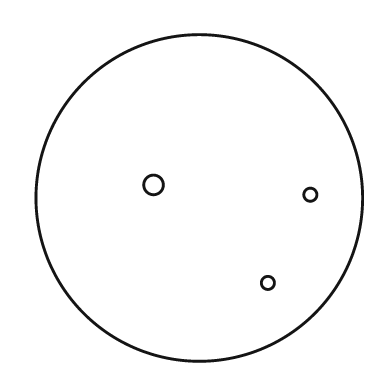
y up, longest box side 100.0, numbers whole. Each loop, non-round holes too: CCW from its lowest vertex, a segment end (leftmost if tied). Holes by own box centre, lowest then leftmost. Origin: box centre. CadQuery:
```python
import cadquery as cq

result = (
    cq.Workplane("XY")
    .moveTo(0.0, 0.0)
    .circle(50.0)
    .moveTo(21.0, -26.0)
    .circle(2.0)
    .moveTo(34.0, 1.0)
    .circle(2.0)
    .moveTo(-14.0, 4.0)
    .circle(3.0)
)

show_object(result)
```